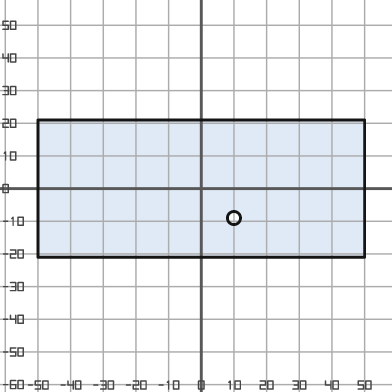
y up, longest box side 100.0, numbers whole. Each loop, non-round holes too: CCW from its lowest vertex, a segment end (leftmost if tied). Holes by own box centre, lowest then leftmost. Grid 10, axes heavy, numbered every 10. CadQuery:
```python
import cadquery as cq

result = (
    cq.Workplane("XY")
    .moveTo(-50.0, -21.0)
    .lineTo(50.0, -21.0)
    .lineTo(50.0, 21.0)
    .lineTo(-50.0, 21.0)
    .close()
    .moveTo(10.0, -9.0)
    .circle(2.0)
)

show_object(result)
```